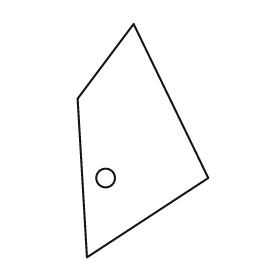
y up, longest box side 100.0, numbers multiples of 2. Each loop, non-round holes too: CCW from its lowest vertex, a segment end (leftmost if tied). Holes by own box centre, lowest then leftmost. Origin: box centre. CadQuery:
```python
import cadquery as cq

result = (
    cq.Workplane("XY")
    .moveTo(-24.0, -50.0)
    .lineTo(28.0, -16.0)
    .lineTo(-4.0, 50.0)
    .lineTo(-28.0, 18.0)
    .close()
    .moveTo(-16.0, -16.0)
    .circle(4.0)
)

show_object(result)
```